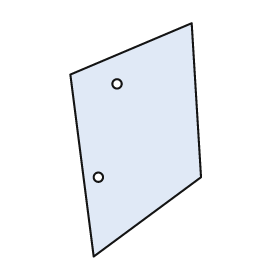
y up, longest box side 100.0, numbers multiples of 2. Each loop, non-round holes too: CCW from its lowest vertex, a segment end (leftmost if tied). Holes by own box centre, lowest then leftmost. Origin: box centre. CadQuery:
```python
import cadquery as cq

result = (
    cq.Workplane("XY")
    .moveTo(-18.0, -50.0)
    .lineTo(28.0, -16.0)
    .lineTo(24.0, 50.0)
    .lineTo(-28.0, 28.0)
    .close()
    .moveTo(-16.0, -16.0)
    .circle(2.0)
    .moveTo(-8.0, 24.0)
    .circle(2.0)
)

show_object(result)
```